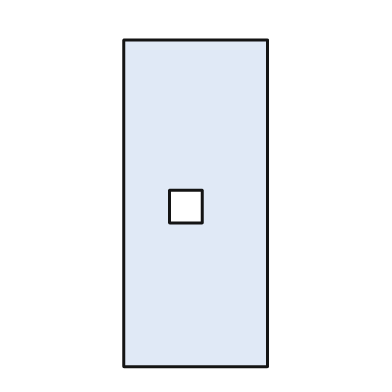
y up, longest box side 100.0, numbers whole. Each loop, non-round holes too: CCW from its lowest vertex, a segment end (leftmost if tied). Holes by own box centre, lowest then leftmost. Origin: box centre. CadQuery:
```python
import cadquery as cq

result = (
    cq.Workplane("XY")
    .moveTo(-22.0, -50.0)
    .lineTo(22.0, -50.0)
    .lineTo(22.0, 50.0)
    .lineTo(-22.0, 50.0)
    .close()
    .moveTo(-8.0, -6.0)
    .lineTo(2.0, -6.0)
    .lineTo(2.0, 4.0)
    .lineTo(-8.0, 4.0)
    .close()
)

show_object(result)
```